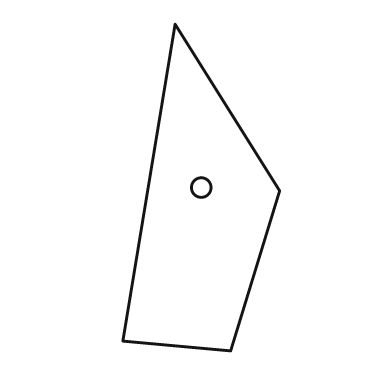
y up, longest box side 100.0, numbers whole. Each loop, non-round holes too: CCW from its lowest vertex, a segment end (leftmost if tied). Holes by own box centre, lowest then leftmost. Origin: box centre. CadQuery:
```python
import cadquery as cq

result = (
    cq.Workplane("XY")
    .moveTo(9.0, -50.0)
    .lineTo(24.0, -1.0)
    .lineTo(-8.0, 50.0)
    .lineTo(-24.0, -47.0)
    .close()
    .moveTo(0.0, 0.0)
    .circle(3.0)
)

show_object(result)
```